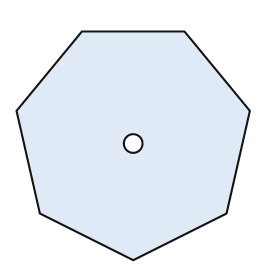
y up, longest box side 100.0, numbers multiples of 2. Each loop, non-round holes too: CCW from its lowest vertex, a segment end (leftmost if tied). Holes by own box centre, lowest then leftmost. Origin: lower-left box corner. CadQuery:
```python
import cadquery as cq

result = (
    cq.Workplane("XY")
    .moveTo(50.0, 0.0)
    .lineTo(90.0, 20.0)
    .lineTo(100.0, 64.0)
    .lineTo(72.0, 98.0)
    .lineTo(28.0, 98.0)
    .lineTo(0.0, 64.0)
    .lineTo(10.0, 20.0)
    .close()
    .moveTo(50.0, 50.0)
    .circle(4.0)
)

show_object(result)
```